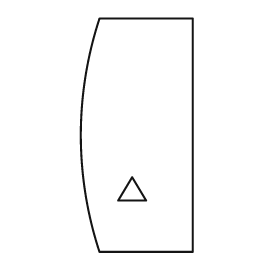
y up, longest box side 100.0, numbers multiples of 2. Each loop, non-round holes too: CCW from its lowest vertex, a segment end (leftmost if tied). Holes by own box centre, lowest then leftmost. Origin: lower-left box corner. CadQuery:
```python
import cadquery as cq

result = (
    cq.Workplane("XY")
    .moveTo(8.0, 0.0)
    .lineTo(48.0, 0.0)
    .lineTo(48.0, 100.0)
    .lineTo(8.0, 100.0)
    .threePointArc((0.0, 50.0), (8.0, 0.0))
    .close()
    .moveTo(16.0, 22.0)
    .lineTo(28.0, 22.0)
    .lineTo(22.0, 32.0)
    .close()
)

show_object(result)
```